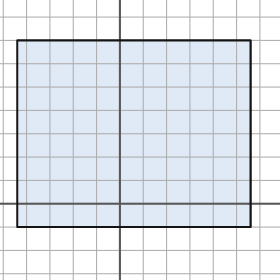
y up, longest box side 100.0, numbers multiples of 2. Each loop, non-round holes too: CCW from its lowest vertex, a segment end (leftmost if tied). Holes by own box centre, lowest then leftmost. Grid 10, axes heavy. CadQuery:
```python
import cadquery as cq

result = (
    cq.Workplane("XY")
    .moveTo(-44.0, -10.0)
    .lineTo(56.0, -10.0)
    .lineTo(56.0, 70.0)
    .lineTo(-44.0, 70.0)
    .close()
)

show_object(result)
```